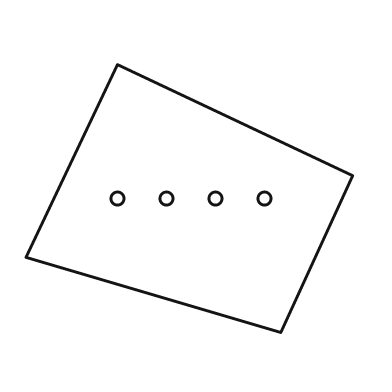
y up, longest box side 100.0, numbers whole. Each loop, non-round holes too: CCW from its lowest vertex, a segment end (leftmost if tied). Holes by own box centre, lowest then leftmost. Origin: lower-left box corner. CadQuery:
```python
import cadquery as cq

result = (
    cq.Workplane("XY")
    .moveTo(78.0, 0.0)
    .lineTo(100.0, 48.0)
    .lineTo(28.0, 82.0)
    .lineTo(0.0, 23.0)
    .close()
    .moveTo(28.0, 41.0)
    .circle(2.0)
    .moveTo(43.0, 41.0)
    .circle(2.0)
    .moveTo(58.0, 41.0)
    .circle(2.0)
    .moveTo(73.0, 41.0)
    .circle(2.0)
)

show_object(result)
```